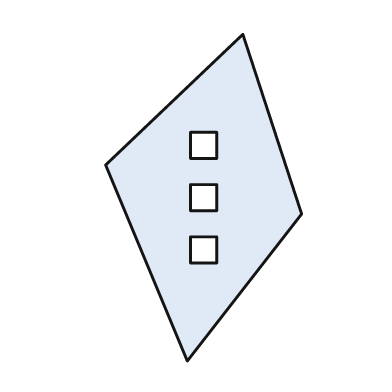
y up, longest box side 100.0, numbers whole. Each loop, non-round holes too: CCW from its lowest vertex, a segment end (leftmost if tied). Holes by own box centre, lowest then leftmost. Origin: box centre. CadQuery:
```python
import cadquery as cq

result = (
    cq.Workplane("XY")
    .moveTo(-5.0, -50.0)
    .lineTo(30.0, -5.0)
    .lineTo(12.0, 50.0)
    .lineTo(-30.0, 10.0)
    .close()
    .moveTo(-4.0, -20.0)
    .lineTo(4.0, -20.0)
    .lineTo(4.0, -12.0)
    .lineTo(-4.0, -12.0)
    .close()
    .moveTo(-4.0, -4.0)
    .lineTo(4.0, -4.0)
    .lineTo(4.0, 4.0)
    .lineTo(-4.0, 4.0)
    .close()
    .moveTo(-4.0, 12.0)
    .lineTo(4.0, 12.0)
    .lineTo(4.0, 20.0)
    .lineTo(-4.0, 20.0)
    .close()
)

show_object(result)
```